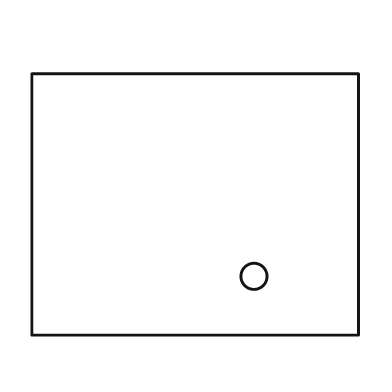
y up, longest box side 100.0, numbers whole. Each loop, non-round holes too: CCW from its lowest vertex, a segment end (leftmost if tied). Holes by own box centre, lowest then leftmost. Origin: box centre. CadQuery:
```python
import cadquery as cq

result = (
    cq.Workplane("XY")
    .moveTo(-50.0, -40.0)
    .lineTo(50.0, -40.0)
    .lineTo(50.0, 40.0)
    .lineTo(-50.0, 40.0)
    .close()
    .moveTo(18.0, -22.0)
    .circle(4.0)
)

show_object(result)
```